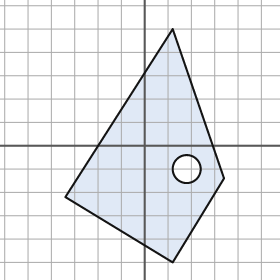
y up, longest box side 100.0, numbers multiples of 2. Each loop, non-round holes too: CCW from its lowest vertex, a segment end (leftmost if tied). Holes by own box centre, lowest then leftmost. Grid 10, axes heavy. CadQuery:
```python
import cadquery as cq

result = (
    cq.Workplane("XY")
    .moveTo(12.0, -50.0)
    .lineTo(34.0, -14.0)
    .lineTo(12.0, 50.0)
    .lineTo(-34.0, -22.0)
    .close()
    .moveTo(18.0, -10.0)
    .circle(6.0)
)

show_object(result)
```